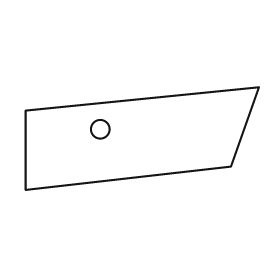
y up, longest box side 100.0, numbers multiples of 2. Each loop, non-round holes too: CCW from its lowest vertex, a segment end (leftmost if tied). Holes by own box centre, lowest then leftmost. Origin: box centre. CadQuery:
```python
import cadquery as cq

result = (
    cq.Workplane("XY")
    .moveTo(-50.0, -22.0)
    .lineTo(38.0, -12.0)
    .lineTo(50.0, 22.0)
    .lineTo(-50.0, 12.0)
    .close()
    .moveTo(-18.0, 4.0)
    .circle(4.0)
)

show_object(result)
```